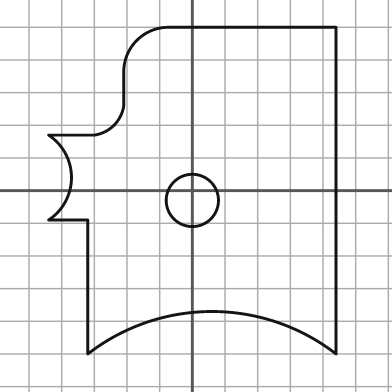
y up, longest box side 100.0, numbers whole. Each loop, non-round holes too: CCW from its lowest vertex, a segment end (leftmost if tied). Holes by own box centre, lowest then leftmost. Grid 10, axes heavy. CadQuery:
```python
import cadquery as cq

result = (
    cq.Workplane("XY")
    .moveTo(-32.0, -50.0)
    .threePointArc((6.0, -37.0), (44.0, -50.0))
    .lineTo(44.0, 50.0)
    .lineTo(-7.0, 50.0)
    .threePointArc((-17.0, 46.0), (-21.0, 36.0))
    .lineTo(-21.0, 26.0)
    .threePointArc((-24.0, 20.0), (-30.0, 17.0))
    .lineTo(-44.0, 17.0)
    .threePointArc((-37.0, 4.0), (-44.0, -9.0))
    .lineTo(-32.0, -9.0)
    .close()
    .moveTo(0.0, -3.0)
    .circle(8.0)
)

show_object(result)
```